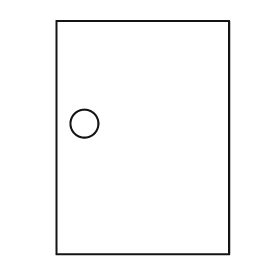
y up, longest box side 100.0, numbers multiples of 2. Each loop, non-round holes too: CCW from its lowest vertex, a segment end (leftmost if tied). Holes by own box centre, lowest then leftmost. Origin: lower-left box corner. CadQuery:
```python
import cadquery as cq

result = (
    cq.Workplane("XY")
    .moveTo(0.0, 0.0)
    .lineTo(74.0, 0.0)
    .lineTo(74.0, 100.0)
    .lineTo(0.0, 100.0)
    .close()
    .moveTo(12.0, 56.0)
    .circle(6.0)
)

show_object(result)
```